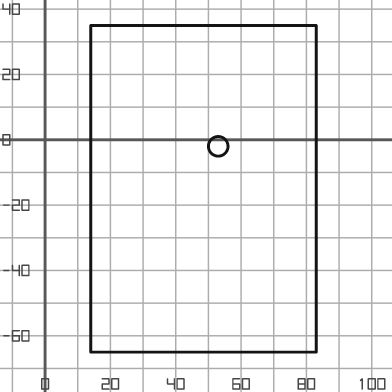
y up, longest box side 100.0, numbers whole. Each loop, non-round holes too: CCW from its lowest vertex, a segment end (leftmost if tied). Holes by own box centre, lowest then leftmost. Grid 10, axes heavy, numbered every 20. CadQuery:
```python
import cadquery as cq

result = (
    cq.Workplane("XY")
    .moveTo(14.0, -65.0)
    .lineTo(83.0, -65.0)
    .lineTo(83.0, 35.0)
    .lineTo(14.0, 35.0)
    .close()
    .moveTo(53.0, -2.0)
    .circle(3.0)
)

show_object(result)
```